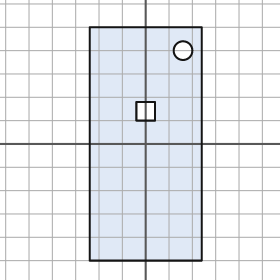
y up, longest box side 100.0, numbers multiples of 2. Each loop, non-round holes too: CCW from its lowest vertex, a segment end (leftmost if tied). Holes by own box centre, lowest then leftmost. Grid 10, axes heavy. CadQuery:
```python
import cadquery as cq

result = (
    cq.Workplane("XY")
    .moveTo(-24.0, -50.0)
    .lineTo(24.0, -50.0)
    .lineTo(24.0, 50.0)
    .lineTo(-24.0, 50.0)
    .close()
    .moveTo(-4.0, 10.0)
    .lineTo(4.0, 10.0)
    .lineTo(4.0, 18.0)
    .lineTo(-4.0, 18.0)
    .close()
    .moveTo(16.0, 40.0)
    .circle(4.0)
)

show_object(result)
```